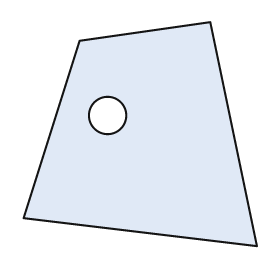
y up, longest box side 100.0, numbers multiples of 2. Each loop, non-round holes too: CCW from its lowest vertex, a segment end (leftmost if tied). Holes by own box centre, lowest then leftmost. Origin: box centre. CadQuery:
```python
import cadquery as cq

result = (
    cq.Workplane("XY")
    .moveTo(50.0, -48.0)
    .lineTo(30.0, 48.0)
    .lineTo(-26.0, 40.0)
    .lineTo(-50.0, -36.0)
    .close()
    .moveTo(-14.0, 8.0)
    .circle(8.0)
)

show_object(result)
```